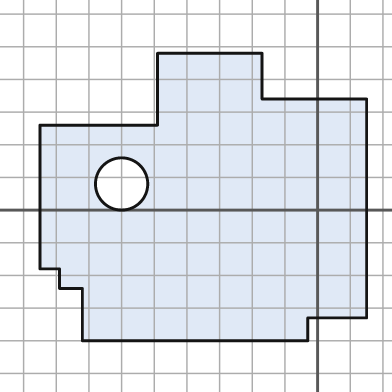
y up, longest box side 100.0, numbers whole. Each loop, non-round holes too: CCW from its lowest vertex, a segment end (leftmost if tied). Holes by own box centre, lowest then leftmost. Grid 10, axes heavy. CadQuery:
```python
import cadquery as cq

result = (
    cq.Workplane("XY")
    .moveTo(-72.0, -40.0)
    .lineTo(-3.0, -40.0)
    .lineTo(-3.0, -33.0)
    .lineTo(15.0, -33.0)
    .lineTo(15.0, 34.0)
    .lineTo(-17.0, 34.0)
    .lineTo(-17.0, 48.0)
    .lineTo(-49.0, 48.0)
    .lineTo(-49.0, 26.0)
    .lineTo(-85.0, 26.0)
    .lineTo(-85.0, -18.0)
    .lineTo(-79.0, -18.0)
    .lineTo(-79.0, -24.0)
    .lineTo(-72.0, -24.0)
    .close()
    .moveTo(-60.0, 8.0)
    .circle(8.0)
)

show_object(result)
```